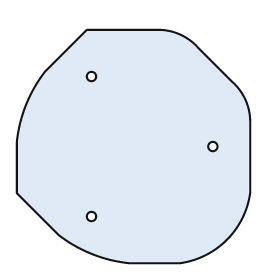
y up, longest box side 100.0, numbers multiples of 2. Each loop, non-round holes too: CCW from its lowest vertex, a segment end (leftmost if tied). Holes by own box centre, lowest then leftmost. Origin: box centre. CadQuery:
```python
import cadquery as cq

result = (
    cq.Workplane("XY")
    .moveTo(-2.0, -50.0)
    .lineTo(20.0, -50.0)
    .threePointArc((40.0, -40.0), (50.0, -20.0))
    .lineTo(50.0, 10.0)
    .threePointArc((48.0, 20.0), (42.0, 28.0))
    .lineTo(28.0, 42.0)
    .threePointArc((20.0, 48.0), (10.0, 50.0))
    .lineTo(-20.0, 50.0)
    .lineTo(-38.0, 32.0)
    .threePointArc((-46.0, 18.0), (-50.0, 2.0))
    .lineTo(-50.0, -20.0)
    .lineTo(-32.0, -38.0)
    .threePointArc((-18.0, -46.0), (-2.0, -50.0))
    .close()
    .moveTo(-18.0, -30.0)
    .circle(2.0)
    .moveTo(34.0, 0.0)
    .circle(2.0)
    .moveTo(-18.0, 30.0)
    .circle(2.0)
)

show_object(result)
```